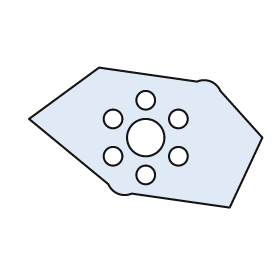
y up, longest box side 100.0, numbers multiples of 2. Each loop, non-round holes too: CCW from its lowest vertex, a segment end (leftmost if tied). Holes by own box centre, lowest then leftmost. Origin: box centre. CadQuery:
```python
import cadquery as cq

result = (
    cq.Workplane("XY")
    .moveTo(36.0, -30.0)
    .lineTo(50.0, 0.0)
    .lineTo(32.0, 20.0)
    .threePointArc((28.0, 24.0), (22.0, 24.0))
    .lineTo(-20.0, 30.0)
    .lineTo(-50.0, 8.0)
    .lineTo(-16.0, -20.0)
    .threePointArc((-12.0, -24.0), (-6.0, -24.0))
    .close()
    .moveTo(0.0, -16.0)
    .circle(4.0)
    .moveTo(-14.0, -8.0)
    .circle(4.0)
    .moveTo(14.0, -8.0)
    .circle(4.0)
    .moveTo(0.0, 0.0)
    .circle(8.0)
    .moveTo(-14.0, 8.0)
    .circle(4.0)
    .moveTo(14.0, 8.0)
    .circle(4.0)
    .moveTo(0.0, 16.0)
    .circle(4.0)
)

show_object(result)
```